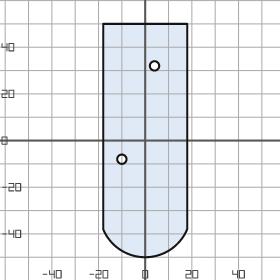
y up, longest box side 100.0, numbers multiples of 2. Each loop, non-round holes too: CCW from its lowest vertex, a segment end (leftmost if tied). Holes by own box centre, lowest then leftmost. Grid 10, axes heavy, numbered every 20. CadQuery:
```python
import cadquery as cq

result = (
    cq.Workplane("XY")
    .moveTo(-18.0, -38.0)
    .threePointArc((0.0, -50.0), (18.0, -38.0))
    .lineTo(18.0, 50.0)
    .lineTo(-18.0, 50.0)
    .close()
    .moveTo(-10.0, -8.0)
    .circle(2.0)
    .moveTo(4.0, 32.0)
    .circle(2.0)
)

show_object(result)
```